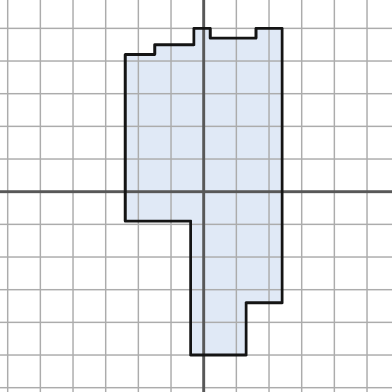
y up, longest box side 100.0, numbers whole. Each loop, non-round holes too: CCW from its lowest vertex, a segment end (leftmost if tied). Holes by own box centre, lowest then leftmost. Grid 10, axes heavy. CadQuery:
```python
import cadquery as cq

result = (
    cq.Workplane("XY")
    .moveTo(-4.0, -50.0)
    .lineTo(13.0, -50.0)
    .lineTo(13.0, -34.0)
    .lineTo(24.0, -34.0)
    .lineTo(24.0, 50.0)
    .lineTo(16.0, 50.0)
    .lineTo(16.0, 47.0)
    .lineTo(2.0, 47.0)
    .lineTo(2.0, 50.0)
    .lineTo(-3.0, 50.0)
    .lineTo(-3.0, 45.0)
    .lineTo(-15.0, 45.0)
    .lineTo(-15.0, 42.0)
    .lineTo(-24.0, 42.0)
    .lineTo(-24.0, -9.0)
    .lineTo(-4.0, -9.0)
    .close()
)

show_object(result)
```